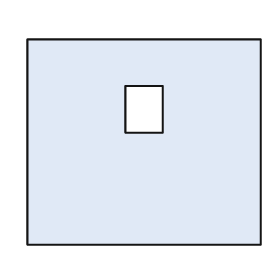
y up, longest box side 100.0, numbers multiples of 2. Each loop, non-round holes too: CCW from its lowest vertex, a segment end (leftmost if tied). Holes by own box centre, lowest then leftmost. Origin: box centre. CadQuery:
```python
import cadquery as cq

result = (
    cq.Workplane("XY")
    .moveTo(-50.0, -44.0)
    .lineTo(50.0, -44.0)
    .lineTo(50.0, 44.0)
    .lineTo(-50.0, 44.0)
    .close()
    .moveTo(-8.0, 4.0)
    .lineTo(8.0, 4.0)
    .lineTo(8.0, 24.0)
    .lineTo(-8.0, 24.0)
    .close()
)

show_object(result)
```